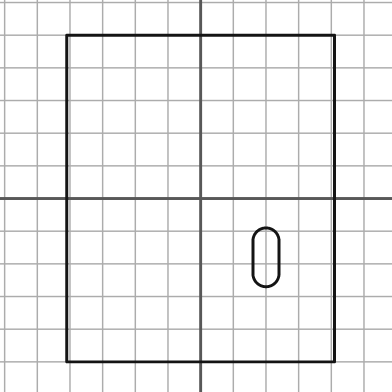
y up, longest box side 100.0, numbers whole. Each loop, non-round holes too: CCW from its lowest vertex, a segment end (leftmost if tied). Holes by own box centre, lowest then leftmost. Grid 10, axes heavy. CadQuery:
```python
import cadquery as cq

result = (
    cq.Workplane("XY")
    .moveTo(-41.0, -50.0)
    .lineTo(41.0, -50.0)
    .lineTo(41.0, 50.0)
    .lineTo(-41.0, 50.0)
    .close()
    .moveTo(16.0, -23.0)
    .threePointArc((20.0, -27.0), (24.0, -23.0))
    .lineTo(24.0, -13.0)
    .threePointArc((20.0, -9.0), (16.0, -13.0))
    .close()
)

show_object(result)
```